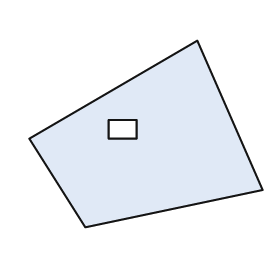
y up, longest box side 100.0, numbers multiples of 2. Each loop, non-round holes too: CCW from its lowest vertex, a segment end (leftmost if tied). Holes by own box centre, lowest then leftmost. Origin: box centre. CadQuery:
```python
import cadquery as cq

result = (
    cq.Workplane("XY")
    .moveTo(-26.0, -40.0)
    .lineTo(50.0, -24.0)
    .lineTo(22.0, 40.0)
    .lineTo(-50.0, -2.0)
    .close()
    .moveTo(-16.0, -2.0)
    .lineTo(-4.0, -2.0)
    .lineTo(-4.0, 6.0)
    .lineTo(-16.0, 6.0)
    .close()
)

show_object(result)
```